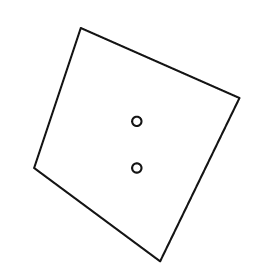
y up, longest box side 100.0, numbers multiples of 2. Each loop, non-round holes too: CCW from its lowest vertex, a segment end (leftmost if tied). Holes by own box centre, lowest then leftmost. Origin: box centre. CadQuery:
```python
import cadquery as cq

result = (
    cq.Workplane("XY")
    .moveTo(10.0, -50.0)
    .lineTo(44.0, 20.0)
    .lineTo(-24.0, 50.0)
    .lineTo(-44.0, -10.0)
    .close()
    .moveTo(0.0, -10.0)
    .circle(2.0)
    .moveTo(0.0, 10.0)
    .circle(2.0)
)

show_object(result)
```